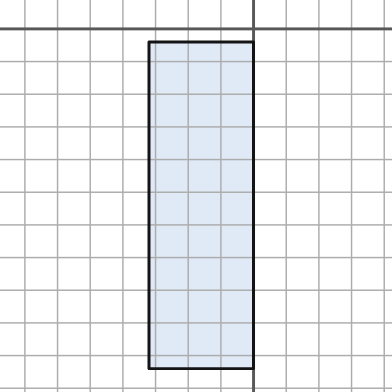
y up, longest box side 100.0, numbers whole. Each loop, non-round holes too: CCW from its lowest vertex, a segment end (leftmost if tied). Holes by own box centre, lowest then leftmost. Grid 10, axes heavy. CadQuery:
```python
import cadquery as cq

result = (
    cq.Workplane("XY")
    .moveTo(-32.0, -104.0)
    .lineTo(0.0, -104.0)
    .lineTo(0.0, -4.0)
    .lineTo(-32.0, -4.0)
    .close()
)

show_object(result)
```